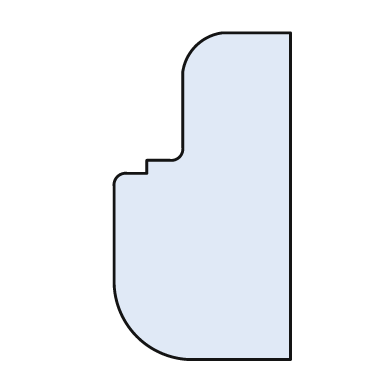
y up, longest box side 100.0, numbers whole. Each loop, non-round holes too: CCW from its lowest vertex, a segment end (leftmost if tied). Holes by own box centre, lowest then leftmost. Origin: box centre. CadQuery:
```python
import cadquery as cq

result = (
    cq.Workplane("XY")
    .moveTo(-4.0, -50.0)
    .lineTo(27.0, -50.0)
    .lineTo(27.0, 50.0)
    .lineTo(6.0, 50.0)
    .threePointArc((-2.0, 46.0), (-6.0, 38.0))
    .lineTo(-6.0, 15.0)
    .threePointArc((-7.0, 12.0), (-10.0, 11.0))
    .lineTo(-17.0, 11.0)
    .lineTo(-17.0, 7.0)
    .lineTo(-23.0, 7.0)
    .threePointArc((-26.0, 6.0), (-27.0, 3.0))
    .lineTo(-27.0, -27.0)
    .threePointArc((-20.0, -43.0), (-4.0, -50.0))
    .close()
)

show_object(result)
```